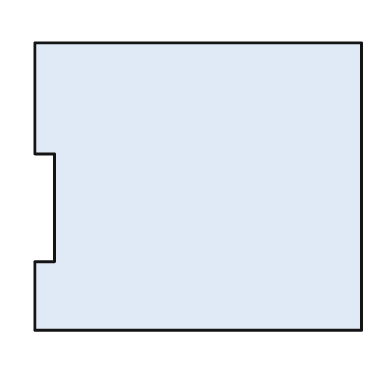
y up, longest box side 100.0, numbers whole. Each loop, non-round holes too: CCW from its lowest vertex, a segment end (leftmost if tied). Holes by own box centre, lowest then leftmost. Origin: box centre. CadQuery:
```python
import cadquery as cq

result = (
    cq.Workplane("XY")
    .moveTo(-50.0, -44.0)
    .lineTo(50.0, -44.0)
    .lineTo(50.0, 44.0)
    .lineTo(-50.0, 44.0)
    .lineTo(-50.0, 10.0)
    .lineTo(-44.0, 10.0)
    .lineTo(-44.0, -23.0)
    .lineTo(-50.0, -23.0)
    .close()
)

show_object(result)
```